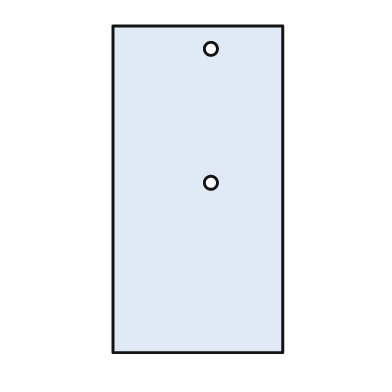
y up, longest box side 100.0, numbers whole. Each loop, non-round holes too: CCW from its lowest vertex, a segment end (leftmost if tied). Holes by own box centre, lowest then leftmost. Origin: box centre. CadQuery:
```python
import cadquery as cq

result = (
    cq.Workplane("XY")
    .moveTo(-26.0, -50.0)
    .lineTo(26.0, -50.0)
    .lineTo(26.0, 50.0)
    .lineTo(-26.0, 50.0)
    .close()
    .moveTo(4.0, 2.0)
    .circle(2.0)
    .moveTo(4.0, 43.0)
    .circle(2.0)
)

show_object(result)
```